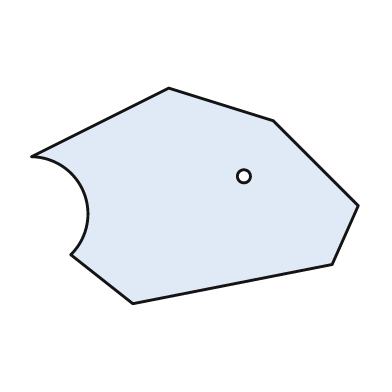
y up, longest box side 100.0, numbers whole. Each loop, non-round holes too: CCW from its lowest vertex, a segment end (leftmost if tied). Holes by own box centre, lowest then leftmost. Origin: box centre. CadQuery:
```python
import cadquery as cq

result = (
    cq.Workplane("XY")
    .moveTo(-19.0, -33.0)
    .lineTo(42.0, -21.0)
    .lineTo(50.0, -3.0)
    .lineTo(24.0, 23.0)
    .lineTo(-8.0, 33.0)
    .lineTo(-50.0, 12.0)
    .threePointArc((-34.0, 1.0), (-38.0, -18.0))
    .close()
    .moveTo(15.0, 6.0)
    .circle(2.0)
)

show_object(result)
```